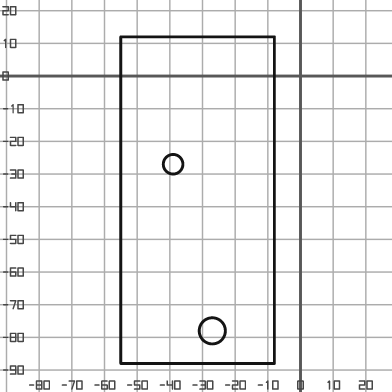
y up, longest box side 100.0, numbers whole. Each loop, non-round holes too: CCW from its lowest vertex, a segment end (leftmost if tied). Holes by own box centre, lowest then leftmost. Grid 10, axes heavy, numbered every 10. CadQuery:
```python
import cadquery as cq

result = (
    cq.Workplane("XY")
    .moveTo(-55.0, -88.0)
    .lineTo(-8.0, -88.0)
    .lineTo(-8.0, 12.0)
    .lineTo(-55.0, 12.0)
    .close()
    .moveTo(-27.0, -78.0)
    .circle(4.0)
    .moveTo(-39.0, -27.0)
    .circle(3.0)
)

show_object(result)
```